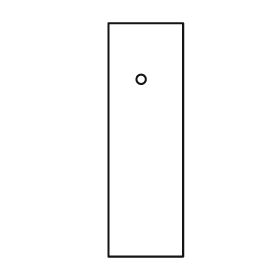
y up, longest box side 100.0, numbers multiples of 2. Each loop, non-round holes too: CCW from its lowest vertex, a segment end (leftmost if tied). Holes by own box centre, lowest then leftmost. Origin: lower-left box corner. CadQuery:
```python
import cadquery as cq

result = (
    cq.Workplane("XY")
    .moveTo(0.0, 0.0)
    .lineTo(32.0, 0.0)
    .lineTo(32.0, 100.0)
    .lineTo(0.0, 100.0)
    .close()
    .moveTo(14.0, 76.0)
    .circle(2.0)
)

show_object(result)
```